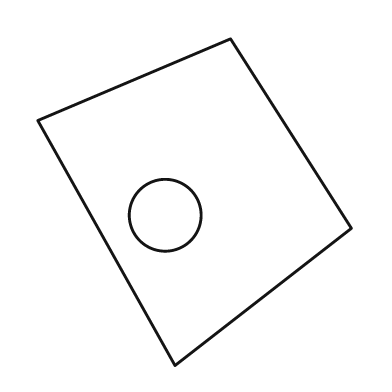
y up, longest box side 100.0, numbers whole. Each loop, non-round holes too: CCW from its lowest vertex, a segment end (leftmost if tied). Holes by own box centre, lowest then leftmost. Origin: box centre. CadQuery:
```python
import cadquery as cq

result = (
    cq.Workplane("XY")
    .moveTo(-6.0, -50.0)
    .lineTo(48.0, -8.0)
    .lineTo(11.0, 50.0)
    .lineTo(-48.0, 25.0)
    .close()
    .moveTo(-9.0, -4.0)
    .circle(11.0)
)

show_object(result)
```